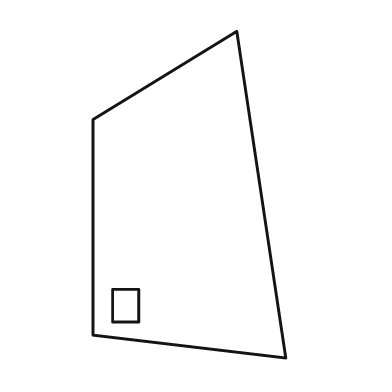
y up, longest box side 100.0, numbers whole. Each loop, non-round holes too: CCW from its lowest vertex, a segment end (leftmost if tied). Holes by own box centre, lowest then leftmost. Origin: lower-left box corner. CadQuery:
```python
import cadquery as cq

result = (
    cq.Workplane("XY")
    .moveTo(59.0, 0.0)
    .lineTo(44.0, 100.0)
    .lineTo(0.0, 73.0)
    .lineTo(0.0, 7.0)
    .close()
    .moveTo(6.0, 11.0)
    .lineTo(14.0, 11.0)
    .lineTo(14.0, 21.0)
    .lineTo(6.0, 21.0)
    .close()
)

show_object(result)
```